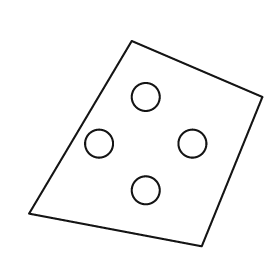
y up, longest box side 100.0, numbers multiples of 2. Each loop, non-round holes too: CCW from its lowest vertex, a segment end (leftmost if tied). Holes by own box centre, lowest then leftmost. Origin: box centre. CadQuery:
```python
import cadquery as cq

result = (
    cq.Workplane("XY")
    .moveTo(24.0, -44.0)
    .lineTo(50.0, 20.0)
    .lineTo(-6.0, 44.0)
    .lineTo(-50.0, -30.0)
    .close()
    .moveTo(0.0, -20.0)
    .circle(6.0)
    .moveTo(-20.0, 0.0)
    .circle(6.0)
    .moveTo(20.0, 0.0)
    .circle(6.0)
    .moveTo(0.0, 20.0)
    .circle(6.0)
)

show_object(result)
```